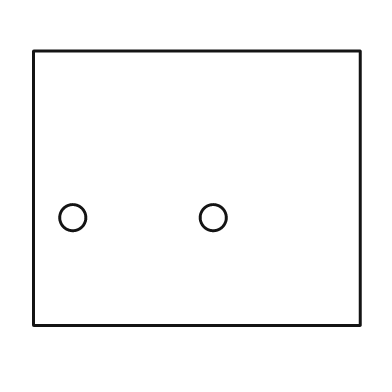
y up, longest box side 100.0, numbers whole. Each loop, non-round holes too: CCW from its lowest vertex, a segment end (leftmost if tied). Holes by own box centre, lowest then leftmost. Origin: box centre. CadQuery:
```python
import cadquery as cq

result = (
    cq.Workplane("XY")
    .moveTo(-50.0, -42.0)
    .lineTo(50.0, -42.0)
    .lineTo(50.0, 42.0)
    .lineTo(-50.0, 42.0)
    .close()
    .moveTo(-38.0, -9.0)
    .circle(4.0)
    .moveTo(5.0, -9.0)
    .circle(4.0)
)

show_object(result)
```